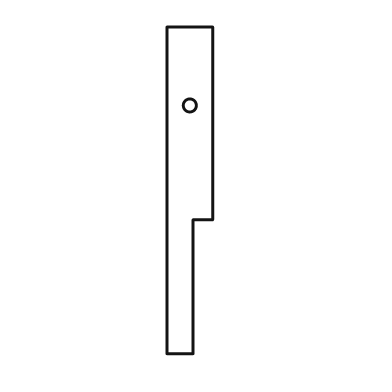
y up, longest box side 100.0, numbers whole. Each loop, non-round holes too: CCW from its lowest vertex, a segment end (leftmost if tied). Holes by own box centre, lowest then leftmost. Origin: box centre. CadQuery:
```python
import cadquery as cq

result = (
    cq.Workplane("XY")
    .moveTo(-7.0, -50.0)
    .lineTo(1.0, -50.0)
    .lineTo(1.0, -9.0)
    .lineTo(7.0, -9.0)
    .lineTo(7.0, 50.0)
    .lineTo(-7.0, 50.0)
    .close()
    .moveTo(0.0, 26.0)
    .circle(2.0)
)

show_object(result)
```